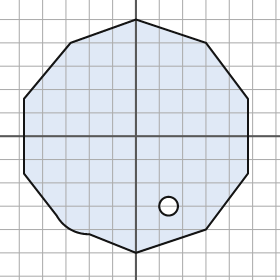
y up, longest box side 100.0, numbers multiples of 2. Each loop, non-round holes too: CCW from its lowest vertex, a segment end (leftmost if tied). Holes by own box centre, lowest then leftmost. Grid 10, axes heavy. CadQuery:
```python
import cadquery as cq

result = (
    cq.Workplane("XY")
    .moveTo(0.0, -50.0)
    .lineTo(30.0, -40.0)
    .lineTo(48.0, -16.0)
    .lineTo(48.0, 16.0)
    .lineTo(30.0, 40.0)
    .lineTo(0.0, 50.0)
    .lineTo(-28.0, 40.0)
    .lineTo(-48.0, 16.0)
    .lineTo(-48.0, -16.0)
    .lineTo(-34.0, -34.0)
    .threePointArc((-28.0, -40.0), (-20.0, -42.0))
    .close()
    .moveTo(14.0, -30.0)
    .circle(4.0)
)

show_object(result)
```